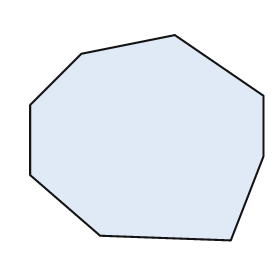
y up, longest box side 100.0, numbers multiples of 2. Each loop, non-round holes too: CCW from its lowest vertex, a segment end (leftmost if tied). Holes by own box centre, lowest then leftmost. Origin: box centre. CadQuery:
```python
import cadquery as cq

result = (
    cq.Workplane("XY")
    .moveTo(36.0, -44.0)
    .lineTo(50.0, -8.0)
    .lineTo(50.0, 18.0)
    .lineTo(12.0, 44.0)
    .lineTo(-28.0, 36.0)
    .lineTo(-50.0, 14.0)
    .lineTo(-50.0, -16.0)
    .lineTo(-20.0, -42.0)
    .close()
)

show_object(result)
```